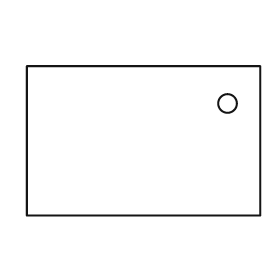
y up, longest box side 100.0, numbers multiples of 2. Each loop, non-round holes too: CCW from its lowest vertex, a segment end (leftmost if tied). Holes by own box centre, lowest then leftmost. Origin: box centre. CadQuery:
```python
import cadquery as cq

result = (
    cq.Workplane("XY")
    .moveTo(-50.0, -32.0)
    .lineTo(50.0, -32.0)
    .lineTo(50.0, 32.0)
    .lineTo(-50.0, 32.0)
    .close()
    .moveTo(36.0, 16.0)
    .circle(4.0)
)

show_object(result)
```